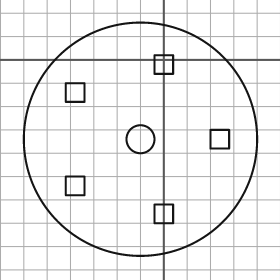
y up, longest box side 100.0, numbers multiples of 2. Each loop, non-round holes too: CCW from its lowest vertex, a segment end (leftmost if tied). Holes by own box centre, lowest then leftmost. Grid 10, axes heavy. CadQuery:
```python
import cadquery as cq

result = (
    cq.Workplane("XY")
    .moveTo(-10.0, -34.0)
    .circle(50.0)
    .moveTo(-4.0, -70.0)
    .lineTo(4.0, -70.0)
    .lineTo(4.0, -62.0)
    .lineTo(-4.0, -62.0)
    .close()
    .moveTo(-42.0, -58.0)
    .lineTo(-34.0, -58.0)
    .lineTo(-34.0, -50.0)
    .lineTo(-42.0, -50.0)
    .close()
    .moveTo(-10.0, -34.0)
    .circle(6.0)
    .moveTo(20.0, -38.0)
    .lineTo(28.0, -38.0)
    .lineTo(28.0, -30.0)
    .lineTo(20.0, -30.0)
    .close()
    .moveTo(-42.0, -18.0)
    .lineTo(-34.0, -18.0)
    .lineTo(-34.0, -10.0)
    .lineTo(-42.0, -10.0)
    .close()
    .moveTo(-4.0, -6.0)
    .lineTo(4.0, -6.0)
    .lineTo(4.0, 2.0)
    .lineTo(-4.0, 2.0)
    .close()
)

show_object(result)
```